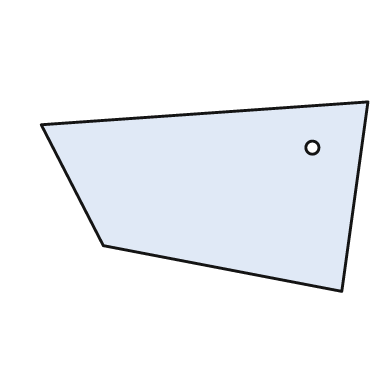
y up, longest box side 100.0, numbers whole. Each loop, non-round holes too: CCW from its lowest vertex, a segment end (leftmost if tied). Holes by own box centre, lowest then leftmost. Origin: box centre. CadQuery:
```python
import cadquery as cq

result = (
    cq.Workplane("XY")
    .moveTo(42.0, -29.0)
    .lineTo(50.0, 29.0)
    .lineTo(-50.0, 22.0)
    .lineTo(-31.0, -15.0)
    .close()
    .moveTo(33.0, 15.0)
    .circle(2.0)
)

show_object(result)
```